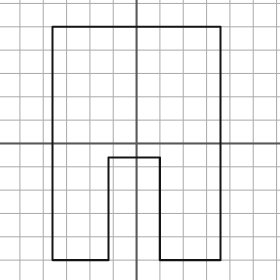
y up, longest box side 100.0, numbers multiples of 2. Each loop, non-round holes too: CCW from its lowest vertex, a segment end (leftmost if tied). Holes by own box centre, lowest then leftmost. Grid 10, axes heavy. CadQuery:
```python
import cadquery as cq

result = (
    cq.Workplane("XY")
    .moveTo(-36.0, -50.0)
    .lineTo(-12.0, -50.0)
    .lineTo(-12.0, -6.0)
    .lineTo(10.0, -6.0)
    .lineTo(10.0, -50.0)
    .lineTo(36.0, -50.0)
    .lineTo(36.0, 50.0)
    .lineTo(-36.0, 50.0)
    .close()
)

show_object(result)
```